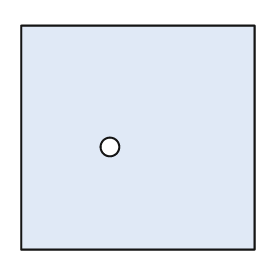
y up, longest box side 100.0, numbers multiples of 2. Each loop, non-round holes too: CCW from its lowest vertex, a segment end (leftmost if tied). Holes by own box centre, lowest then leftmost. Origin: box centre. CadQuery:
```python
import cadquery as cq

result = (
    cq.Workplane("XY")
    .moveTo(-50.0, -48.0)
    .lineTo(50.0, -48.0)
    .lineTo(50.0, 48.0)
    .lineTo(-50.0, 48.0)
    .close()
    .moveTo(-12.0, -4.0)
    .circle(4.0)
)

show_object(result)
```